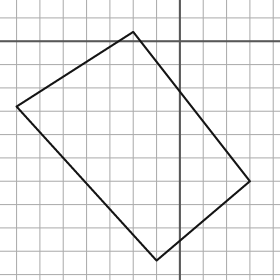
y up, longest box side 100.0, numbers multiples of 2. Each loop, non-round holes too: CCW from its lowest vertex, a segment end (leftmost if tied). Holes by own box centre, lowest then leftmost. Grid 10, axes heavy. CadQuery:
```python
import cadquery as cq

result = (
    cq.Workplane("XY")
    .moveTo(-10.0, -94.0)
    .lineTo(30.0, -60.0)
    .lineTo(-20.0, 4.0)
    .lineTo(-70.0, -28.0)
    .close()
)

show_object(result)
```